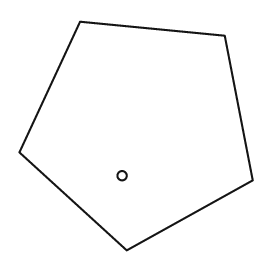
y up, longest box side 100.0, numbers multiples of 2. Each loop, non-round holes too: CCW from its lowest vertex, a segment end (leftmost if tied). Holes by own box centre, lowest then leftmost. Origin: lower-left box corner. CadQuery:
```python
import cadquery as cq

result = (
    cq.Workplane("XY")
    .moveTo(46.0, 0.0)
    .lineTo(100.0, 30.0)
    .lineTo(88.0, 92.0)
    .lineTo(26.0, 98.0)
    .lineTo(0.0, 42.0)
    .close()
    .moveTo(44.0, 32.0)
    .circle(2.0)
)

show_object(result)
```